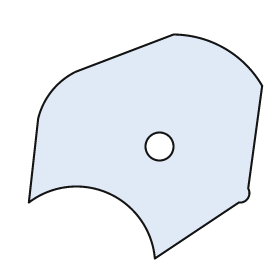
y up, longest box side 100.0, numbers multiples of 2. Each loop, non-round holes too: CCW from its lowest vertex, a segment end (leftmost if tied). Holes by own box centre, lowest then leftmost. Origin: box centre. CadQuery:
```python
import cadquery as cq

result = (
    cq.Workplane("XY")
    .moveTo(4.0, -48.0)
    .lineTo(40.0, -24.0)
    .threePointArc((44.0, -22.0), (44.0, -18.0))
    .lineTo(50.0, 26.0)
    .threePointArc((34.0, 42.0), (12.0, 48.0))
    .lineTo(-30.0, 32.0)
    .threePointArc((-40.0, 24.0), (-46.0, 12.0))
    .lineTo(-50.0, -24.0)
    .threePointArc((-16.0, -20.0), (4.0, -48.0))
    .close()
    .moveTo(6.0, 0.0)
    .circle(6.0)
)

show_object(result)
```